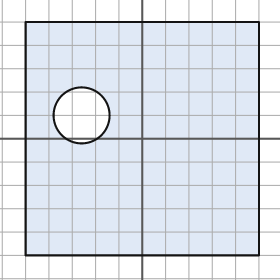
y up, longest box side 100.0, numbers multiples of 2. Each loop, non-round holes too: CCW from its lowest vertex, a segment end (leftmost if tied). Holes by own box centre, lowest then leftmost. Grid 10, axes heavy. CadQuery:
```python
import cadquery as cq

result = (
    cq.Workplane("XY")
    .moveTo(-50.0, -50.0)
    .lineTo(50.0, -50.0)
    .lineTo(50.0, 50.0)
    .lineTo(-50.0, 50.0)
    .close()
    .moveTo(-26.0, 10.0)
    .circle(12.0)
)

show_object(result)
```